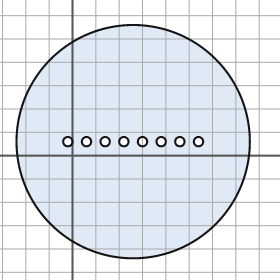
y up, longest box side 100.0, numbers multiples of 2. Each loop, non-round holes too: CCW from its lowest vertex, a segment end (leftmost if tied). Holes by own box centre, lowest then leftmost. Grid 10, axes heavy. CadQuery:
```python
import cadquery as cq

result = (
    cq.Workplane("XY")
    .moveTo(26.0, 6.0)
    .circle(50.0)
    .moveTo(-2.0, 6.0)
    .circle(2.0)
    .moveTo(6.0, 6.0)
    .circle(2.0)
    .moveTo(14.0, 6.0)
    .circle(2.0)
    .moveTo(22.0, 6.0)
    .circle(2.0)
    .moveTo(30.0, 6.0)
    .circle(2.0)
    .moveTo(38.0, 6.0)
    .circle(2.0)
    .moveTo(46.0, 6.0)
    .circle(2.0)
    .moveTo(54.0, 6.0)
    .circle(2.0)
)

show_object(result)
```